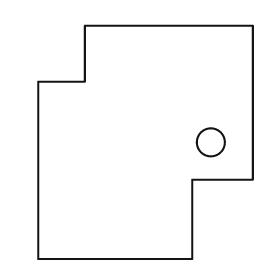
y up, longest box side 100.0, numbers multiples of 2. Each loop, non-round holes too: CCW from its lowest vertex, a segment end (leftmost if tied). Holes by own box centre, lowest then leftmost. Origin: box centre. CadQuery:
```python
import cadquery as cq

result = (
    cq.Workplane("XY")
    .moveTo(-46.0, -50.0)
    .lineTo(20.0, -50.0)
    .lineTo(20.0, -16.0)
    .lineTo(46.0, -16.0)
    .lineTo(46.0, 50.0)
    .lineTo(-26.0, 50.0)
    .lineTo(-26.0, 26.0)
    .lineTo(-46.0, 26.0)
    .close()
    .moveTo(28.0, 0.0)
    .circle(6.0)
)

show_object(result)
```